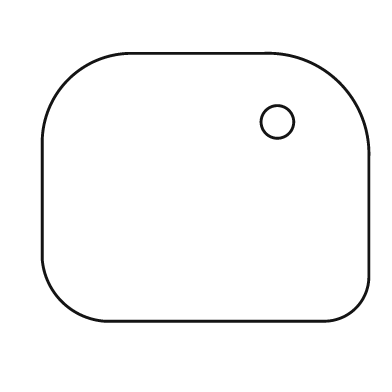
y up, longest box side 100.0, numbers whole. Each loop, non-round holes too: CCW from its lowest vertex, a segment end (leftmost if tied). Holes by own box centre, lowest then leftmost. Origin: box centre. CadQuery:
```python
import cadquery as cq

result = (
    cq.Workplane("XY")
    .moveTo(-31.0, -41.0)
    .lineTo(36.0, -41.0)
    .threePointArc((46.0, -37.0), (50.0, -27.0))
    .lineTo(50.0, 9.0)
    .threePointArc((41.0, 32.0), (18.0, 41.0))
    .lineTo(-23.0, 41.0)
    .threePointArc((-42.0, 33.0), (-50.0, 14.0))
    .lineTo(-50.0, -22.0)
    .threePointArc((-44.0, -35.0), (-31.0, -41.0))
    .close()
    .moveTo(22.0, 20.0)
    .circle(5.0)
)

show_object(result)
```